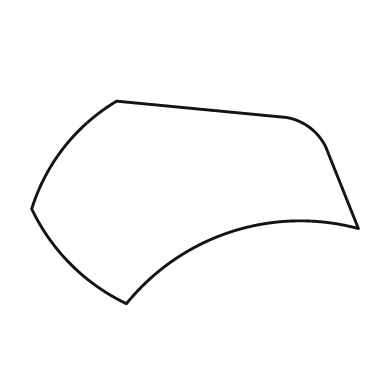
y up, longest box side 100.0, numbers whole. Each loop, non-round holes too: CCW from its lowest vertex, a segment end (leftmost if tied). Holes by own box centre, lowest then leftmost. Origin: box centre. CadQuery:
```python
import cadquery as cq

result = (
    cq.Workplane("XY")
    .moveTo(-21.0, -31.0)
    .threePointArc((11.0, -9.0), (50.0, -8.0))
    .lineTo(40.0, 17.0)
    .threePointArc((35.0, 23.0), (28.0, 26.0))
    .lineTo(-24.0, 31.0)
    .threePointArc((-40.0, 17.0), (-50.0, -2.0))
    .threePointArc((-38.0, -19.0), (-21.0, -31.0))
    .close()
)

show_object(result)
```